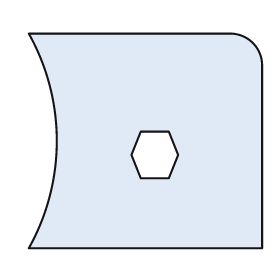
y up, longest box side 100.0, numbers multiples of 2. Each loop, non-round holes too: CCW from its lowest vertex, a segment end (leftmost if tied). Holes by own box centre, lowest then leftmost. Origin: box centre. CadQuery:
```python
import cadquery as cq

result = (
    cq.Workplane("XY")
    .moveTo(-50.0, -46.0)
    .lineTo(50.0, -46.0)
    .lineTo(50.0, 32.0)
    .threePointArc((46.0, 42.0), (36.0, 46.0))
    .lineTo(-50.0, 46.0)
    .threePointArc((-38.0, 0.0), (-50.0, -46.0))
    .close()
    .moveTo(-2.0, -16.0)
    .lineTo(10.0, -16.0)
    .lineTo(14.0, -6.0)
    .lineTo(10.0, 4.0)
    .lineTo(-2.0, 4.0)
    .lineTo(-6.0, -6.0)
    .close()
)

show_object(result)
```